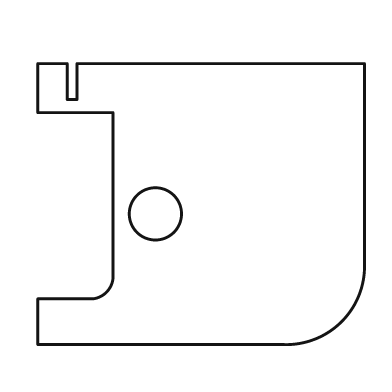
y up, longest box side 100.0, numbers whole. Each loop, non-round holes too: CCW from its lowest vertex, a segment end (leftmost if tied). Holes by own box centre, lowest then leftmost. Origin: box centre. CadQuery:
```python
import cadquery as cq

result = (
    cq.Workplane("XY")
    .moveTo(-50.0, -43.0)
    .lineTo(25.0, -43.0)
    .threePointArc((43.0, -36.0), (50.0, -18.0))
    .lineTo(50.0, 43.0)
    .lineTo(-38.0, 43.0)
    .lineTo(-38.0, 32.0)
    .lineTo(-41.0, 32.0)
    .lineTo(-41.0, 43.0)
    .lineTo(-50.0, 43.0)
    .lineTo(-50.0, 28.0)
    .lineTo(-27.0, 28.0)
    .lineTo(-27.0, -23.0)
    .threePointArc((-29.0, -27.0), (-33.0, -29.0))
    .lineTo(-50.0, -29.0)
    .close()
    .moveTo(-14.0, -3.0)
    .circle(8.0)
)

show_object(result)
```